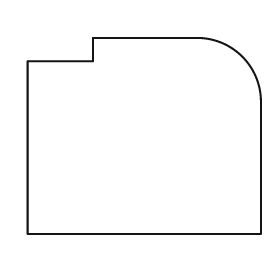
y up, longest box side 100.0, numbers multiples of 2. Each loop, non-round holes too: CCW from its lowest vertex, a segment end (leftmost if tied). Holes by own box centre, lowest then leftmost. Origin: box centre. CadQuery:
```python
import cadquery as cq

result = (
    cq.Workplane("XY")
    .moveTo(-50.0, -42.0)
    .lineTo(50.0, -42.0)
    .lineTo(50.0, 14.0)
    .threePointArc((42.0, 34.0), (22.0, 42.0))
    .lineTo(-22.0, 42.0)
    .lineTo(-22.0, 32.0)
    .lineTo(-50.0, 32.0)
    .close()
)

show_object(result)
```